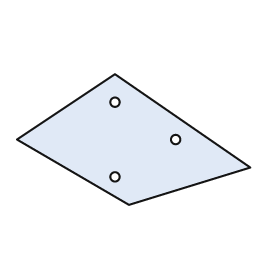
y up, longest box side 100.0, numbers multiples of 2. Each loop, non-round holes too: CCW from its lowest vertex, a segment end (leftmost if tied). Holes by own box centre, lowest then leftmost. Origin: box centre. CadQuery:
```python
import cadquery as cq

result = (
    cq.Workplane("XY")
    .moveTo(-2.0, -28.0)
    .lineTo(50.0, -12.0)
    .lineTo(-8.0, 28.0)
    .lineTo(-50.0, 0.0)
    .close()
    .moveTo(-8.0, -16.0)
    .circle(2.0)
    .moveTo(18.0, 0.0)
    .circle(2.0)
    .moveTo(-8.0, 16.0)
    .circle(2.0)
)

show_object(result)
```